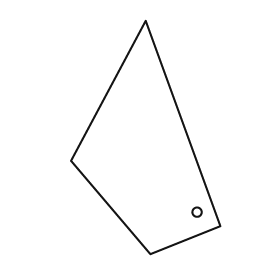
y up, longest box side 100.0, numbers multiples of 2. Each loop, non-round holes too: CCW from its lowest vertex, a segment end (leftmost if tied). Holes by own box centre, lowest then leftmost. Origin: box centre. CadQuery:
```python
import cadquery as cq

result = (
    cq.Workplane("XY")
    .moveTo(2.0, -50.0)
    .lineTo(32.0, -38.0)
    .lineTo(0.0, 50.0)
    .lineTo(-32.0, -10.0)
    .close()
    .moveTo(22.0, -32.0)
    .circle(2.0)
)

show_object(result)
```